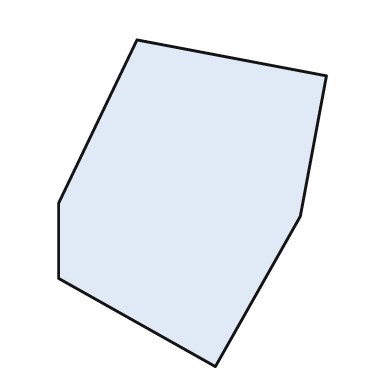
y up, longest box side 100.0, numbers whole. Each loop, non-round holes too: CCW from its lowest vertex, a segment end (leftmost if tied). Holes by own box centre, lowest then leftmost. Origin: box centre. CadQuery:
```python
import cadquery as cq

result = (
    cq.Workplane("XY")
    .moveTo(7.0, -50.0)
    .lineTo(33.0, -4.0)
    .lineTo(41.0, 39.0)
    .lineTo(-17.0, 50.0)
    .lineTo(-41.0, 0.0)
    .lineTo(-41.0, -23.0)
    .close()
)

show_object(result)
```